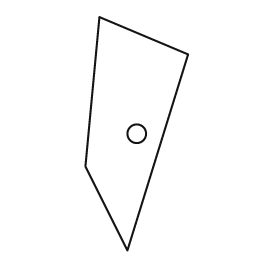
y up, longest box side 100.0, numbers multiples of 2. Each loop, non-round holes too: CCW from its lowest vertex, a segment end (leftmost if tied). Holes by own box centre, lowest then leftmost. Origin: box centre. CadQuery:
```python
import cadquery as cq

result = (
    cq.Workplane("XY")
    .moveTo(-4.0, -50.0)
    .lineTo(22.0, 34.0)
    .lineTo(-16.0, 50.0)
    .lineTo(-22.0, -14.0)
    .close()
    .moveTo(0.0, 0.0)
    .circle(4.0)
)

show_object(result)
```